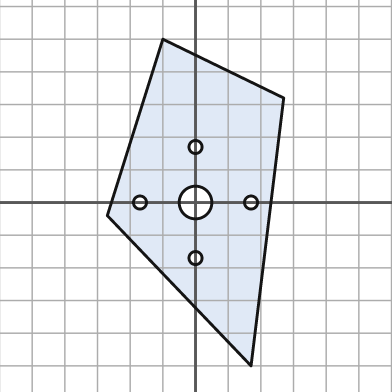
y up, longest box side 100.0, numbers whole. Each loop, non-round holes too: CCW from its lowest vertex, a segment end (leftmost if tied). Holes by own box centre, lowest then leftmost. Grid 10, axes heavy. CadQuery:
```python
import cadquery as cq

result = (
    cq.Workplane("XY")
    .moveTo(17.0, -50.0)
    .lineTo(27.0, 32.0)
    .lineTo(-10.0, 50.0)
    .lineTo(-27.0, -4.0)
    .close()
    .moveTo(0.0, -17.0)
    .circle(2.0)
    .moveTo(-17.0, 0.0)
    .circle(2.0)
    .moveTo(0.0, 0.0)
    .circle(5.0)
    .moveTo(17.0, 0.0)
    .circle(2.0)
    .moveTo(0.0, 17.0)
    .circle(2.0)
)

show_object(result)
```